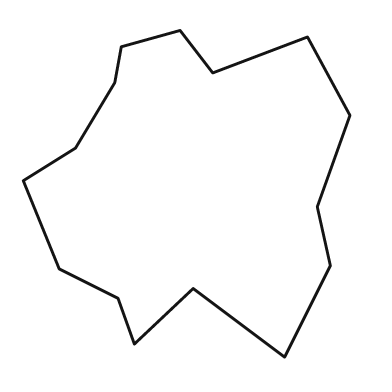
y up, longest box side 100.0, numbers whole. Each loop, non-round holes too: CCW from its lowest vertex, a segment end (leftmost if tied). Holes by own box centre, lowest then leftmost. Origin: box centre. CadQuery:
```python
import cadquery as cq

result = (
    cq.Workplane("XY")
    .moveTo(30.0, -50.0)
    .lineTo(44.0, -22.0)
    .lineTo(40.0, -4.0)
    .lineTo(50.0, 24.0)
    .lineTo(37.0, 48.0)
    .lineTo(8.0, 37.0)
    .lineTo(-2.0, 50.0)
    .lineTo(-20.0, 45.0)
    .lineTo(-22.0, 34.0)
    .lineTo(-34.0, 14.0)
    .lineTo(-50.0, 4.0)
    .lineTo(-39.0, -23.0)
    .lineTo(-21.0, -32.0)
    .lineTo(-16.0, -46.0)
    .lineTo(2.0, -29.0)
    .close()
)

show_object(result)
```